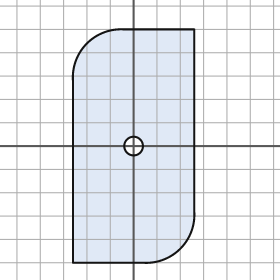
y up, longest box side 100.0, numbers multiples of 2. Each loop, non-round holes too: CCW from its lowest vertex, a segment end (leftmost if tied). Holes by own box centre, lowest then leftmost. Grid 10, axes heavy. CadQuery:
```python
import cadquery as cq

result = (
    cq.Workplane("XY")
    .moveTo(-26.0, -50.0)
    .lineTo(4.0, -50.0)
    .threePointArc((20.0, -44.0), (26.0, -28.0))
    .lineTo(26.0, 50.0)
    .lineTo(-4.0, 50.0)
    .threePointArc((-20.0, 44.0), (-26.0, 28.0))
    .close()
    .moveTo(0.0, 0.0)
    .circle(4.0)
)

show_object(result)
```